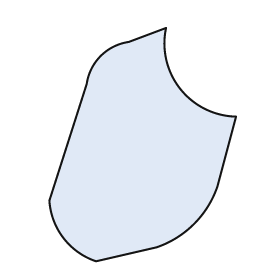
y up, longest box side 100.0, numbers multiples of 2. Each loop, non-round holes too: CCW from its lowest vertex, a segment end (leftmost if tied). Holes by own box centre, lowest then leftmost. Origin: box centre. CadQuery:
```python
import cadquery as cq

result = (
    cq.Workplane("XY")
    .moveTo(-20.0, -50.0)
    .lineTo(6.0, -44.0)
    .threePointArc((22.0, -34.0), (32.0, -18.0))
    .lineTo(40.0, 12.0)
    .threePointArc((16.0, 24.0), (10.0, 50.0))
    .lineTo(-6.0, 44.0)
    .threePointArc((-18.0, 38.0), (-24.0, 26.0))
    .lineTo(-40.0, -24.0)
    .threePointArc((-34.0, -40.0), (-20.0, -50.0))
    .close()
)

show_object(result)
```